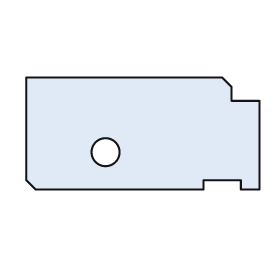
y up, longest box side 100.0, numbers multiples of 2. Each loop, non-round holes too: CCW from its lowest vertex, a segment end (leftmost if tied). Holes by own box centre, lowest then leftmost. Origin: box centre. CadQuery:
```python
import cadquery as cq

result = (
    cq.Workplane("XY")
    .moveTo(-46.0, -24.0)
    .lineTo(26.0, -24.0)
    .lineTo(26.0, -20.0)
    .lineTo(42.0, -20.0)
    .lineTo(42.0, -24.0)
    .lineTo(50.0, -24.0)
    .lineTo(50.0, 14.0)
    .lineTo(38.0, 14.0)
    .lineTo(38.0, 20.0)
    .lineTo(34.0, 24.0)
    .lineTo(-50.0, 24.0)
    .lineTo(-50.0, -20.0)
    .close()
    .moveTo(-16.0, -8.0)
    .circle(6.0)
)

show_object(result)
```